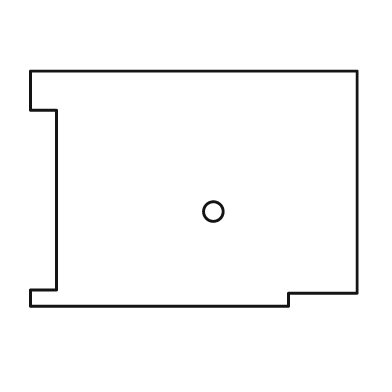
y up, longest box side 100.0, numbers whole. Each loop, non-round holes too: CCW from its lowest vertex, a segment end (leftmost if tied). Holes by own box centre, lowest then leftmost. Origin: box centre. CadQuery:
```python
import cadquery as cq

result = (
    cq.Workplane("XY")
    .moveTo(-50.0, -36.0)
    .lineTo(29.0, -36.0)
    .lineTo(29.0, -32.0)
    .lineTo(50.0, -32.0)
    .lineTo(50.0, 36.0)
    .lineTo(-50.0, 36.0)
    .lineTo(-50.0, 24.0)
    .lineTo(-42.0, 24.0)
    .lineTo(-42.0, -31.0)
    .lineTo(-50.0, -31.0)
    .close()
    .moveTo(6.0, -7.0)
    .circle(3.0)
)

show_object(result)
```